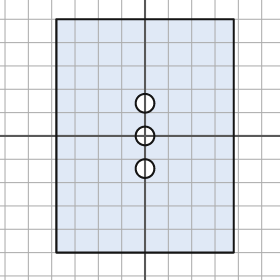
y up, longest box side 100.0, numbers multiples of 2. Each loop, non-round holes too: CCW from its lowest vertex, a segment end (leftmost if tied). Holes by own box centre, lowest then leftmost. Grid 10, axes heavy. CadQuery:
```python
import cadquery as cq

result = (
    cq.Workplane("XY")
    .moveTo(-38.0, -50.0)
    .lineTo(38.0, -50.0)
    .lineTo(38.0, 50.0)
    .lineTo(-38.0, 50.0)
    .close()
    .moveTo(0.0, -14.0)
    .circle(4.0)
    .moveTo(0.0, 0.0)
    .circle(4.0)
    .moveTo(0.0, 14.0)
    .circle(4.0)
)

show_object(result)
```